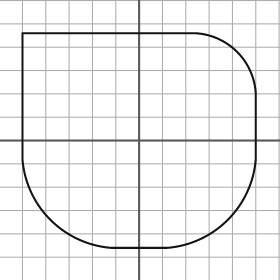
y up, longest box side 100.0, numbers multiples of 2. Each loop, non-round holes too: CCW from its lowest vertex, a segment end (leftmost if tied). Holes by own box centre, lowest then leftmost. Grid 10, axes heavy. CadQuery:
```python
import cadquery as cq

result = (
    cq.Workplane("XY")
    .moveTo(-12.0, -46.0)
    .lineTo(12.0, -46.0)
    .threePointArc((38.0, -34.0), (50.0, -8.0))
    .lineTo(50.0, 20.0)
    .threePointArc((42.0, 38.0), (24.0, 46.0))
    .lineTo(-50.0, 46.0)
    .lineTo(-50.0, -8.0)
    .threePointArc((-38.0, -34.0), (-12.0, -46.0))
    .close()
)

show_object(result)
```